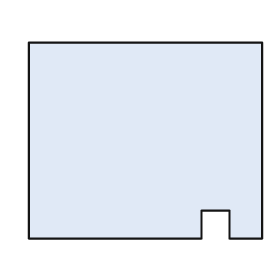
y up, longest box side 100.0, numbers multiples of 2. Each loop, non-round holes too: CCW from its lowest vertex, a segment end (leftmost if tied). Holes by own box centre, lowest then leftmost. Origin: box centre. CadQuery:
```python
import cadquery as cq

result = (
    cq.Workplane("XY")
    .moveTo(-50.0, -42.0)
    .lineTo(24.0, -42.0)
    .lineTo(24.0, -30.0)
    .lineTo(36.0, -30.0)
    .lineTo(36.0, -42.0)
    .lineTo(50.0, -42.0)
    .lineTo(50.0, 42.0)
    .lineTo(-50.0, 42.0)
    .close()
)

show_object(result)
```